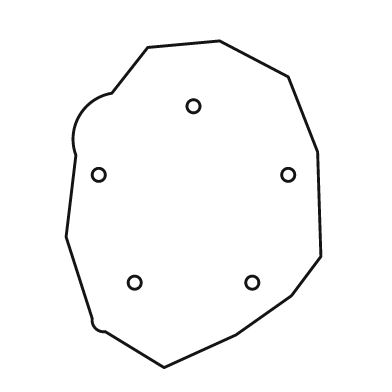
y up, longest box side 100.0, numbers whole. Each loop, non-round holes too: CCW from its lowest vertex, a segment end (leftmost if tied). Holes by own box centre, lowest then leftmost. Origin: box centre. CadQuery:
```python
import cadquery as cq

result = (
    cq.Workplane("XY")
    .moveTo(-9.0, -50.0)
    .lineTo(13.0, -40.0)
    .lineTo(30.0, -28.0)
    .lineTo(39.0, -16.0)
    .lineTo(38.0, 16.0)
    .lineTo(29.0, 39.0)
    .lineTo(8.0, 50.0)
    .lineTo(-14.0, 48.0)
    .lineTo(-25.0, 34.0)
    .threePointArc((-35.0, 27.0), (-36.0, 15.0))
    .lineTo(-39.0, -10.0)
    .lineTo(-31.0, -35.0)
    .threePointArc((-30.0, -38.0), (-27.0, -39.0))
    .close()
    .moveTo(-18.0, -24.0)
    .circle(2.0)
    .moveTo(18.0, -24.0)
    .circle(2.0)
    .moveTo(-29.0, 9.0)
    .circle(2.0)
    .moveTo(29.0, 9.0)
    .circle(2.0)
    .moveTo(0.0, 30.0)
    .circle(2.0)
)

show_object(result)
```